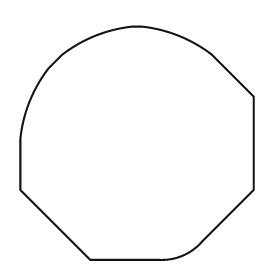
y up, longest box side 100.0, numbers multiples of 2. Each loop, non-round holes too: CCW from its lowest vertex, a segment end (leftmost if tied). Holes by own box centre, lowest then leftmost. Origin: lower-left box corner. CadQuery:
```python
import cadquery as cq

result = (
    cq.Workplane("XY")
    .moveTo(30.0, 0.0)
    .lineTo(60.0, 0.0)
    .threePointArc((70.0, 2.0), (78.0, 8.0))
    .lineTo(100.0, 30.0)
    .lineTo(100.0, 70.0)
    .lineTo(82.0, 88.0)
    .threePointArc((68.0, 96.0), (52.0, 100.0))
    .lineTo(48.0, 100.0)
    .threePointArc((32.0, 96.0), (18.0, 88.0))
    .lineTo(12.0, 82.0)
    .threePointArc((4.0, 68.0), (0.0, 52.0))
    .lineTo(0.0, 30.0)
    .close()
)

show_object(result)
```